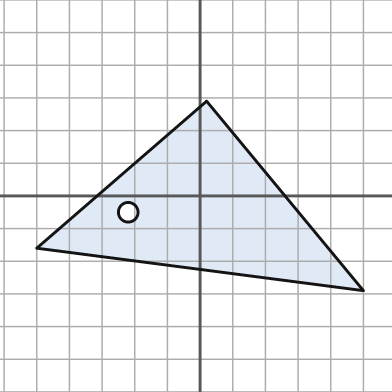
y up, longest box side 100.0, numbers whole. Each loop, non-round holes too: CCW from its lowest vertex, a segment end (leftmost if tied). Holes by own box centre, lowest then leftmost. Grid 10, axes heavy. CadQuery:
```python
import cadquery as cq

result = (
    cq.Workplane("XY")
    .moveTo(50.0, -29.0)
    .lineTo(2.0, 29.0)
    .lineTo(-50.0, -16.0)
    .close()
    .moveTo(-22.0, -5.0)
    .circle(3.0)
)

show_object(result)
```